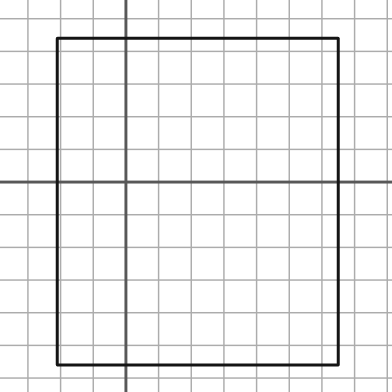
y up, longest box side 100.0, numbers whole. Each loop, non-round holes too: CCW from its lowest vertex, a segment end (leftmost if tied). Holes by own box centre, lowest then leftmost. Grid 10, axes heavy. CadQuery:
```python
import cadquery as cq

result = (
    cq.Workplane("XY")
    .moveTo(-21.0, -56.0)
    .lineTo(65.0, -56.0)
    .lineTo(65.0, 44.0)
    .lineTo(-21.0, 44.0)
    .close()
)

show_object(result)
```